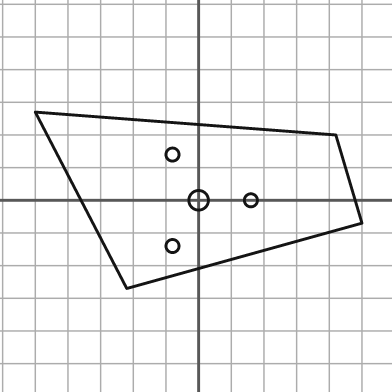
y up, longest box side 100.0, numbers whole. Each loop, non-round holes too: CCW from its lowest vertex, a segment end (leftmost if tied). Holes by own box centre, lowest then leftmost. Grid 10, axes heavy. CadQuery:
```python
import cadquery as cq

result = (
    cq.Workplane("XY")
    .moveTo(-22.0, -27.0)
    .lineTo(50.0, -7.0)
    .lineTo(42.0, 20.0)
    .lineTo(-50.0, 27.0)
    .close()
    .moveTo(-8.0, -14.0)
    .circle(2.0)
    .moveTo(0.0, 0.0)
    .circle(3.0)
    .moveTo(16.0, 0.0)
    .circle(2.0)
    .moveTo(-8.0, 14.0)
    .circle(2.0)
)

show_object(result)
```